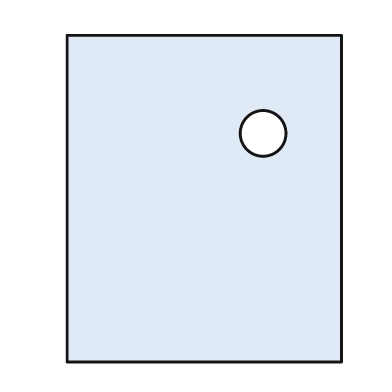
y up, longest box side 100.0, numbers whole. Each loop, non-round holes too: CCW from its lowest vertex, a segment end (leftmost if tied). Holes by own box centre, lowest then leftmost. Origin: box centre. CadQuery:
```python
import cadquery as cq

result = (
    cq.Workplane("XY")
    .moveTo(-42.0, -50.0)
    .lineTo(42.0, -50.0)
    .lineTo(42.0, 50.0)
    .lineTo(-42.0, 50.0)
    .close()
    .moveTo(18.0, 20.0)
    .circle(7.0)
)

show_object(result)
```